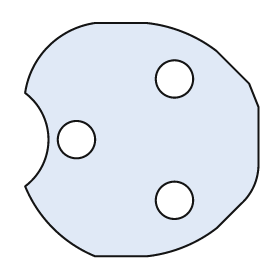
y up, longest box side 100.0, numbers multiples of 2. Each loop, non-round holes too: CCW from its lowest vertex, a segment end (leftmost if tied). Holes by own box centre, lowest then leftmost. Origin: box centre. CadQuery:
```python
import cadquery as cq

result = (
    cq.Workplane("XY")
    .moveTo(-20.0, -50.0)
    .lineTo(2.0, -50.0)
    .threePointArc((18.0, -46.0), (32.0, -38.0))
    .lineTo(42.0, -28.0)
    .threePointArc((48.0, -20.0), (50.0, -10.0))
    .lineTo(50.0, 14.0)
    .lineTo(46.0, 24.0)
    .lineTo(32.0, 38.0)
    .threePointArc((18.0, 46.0), (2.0, 50.0))
    .lineTo(-20.0, 50.0)
    .threePointArc((-40.0, 40.0), (-50.0, 20.0))
    .threePointArc((-40.0, 0.0), (-50.0, -20.0))
    .threePointArc((-38.0, -38.0), (-20.0, -50.0))
    .close()
    .moveTo(14.0, -26.0)
    .circle(8.0)
    .moveTo(-28.0, 0.0)
    .circle(8.0)
    .moveTo(14.0, 26.0)
    .circle(8.0)
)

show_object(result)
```